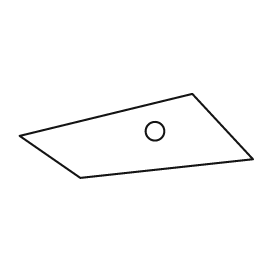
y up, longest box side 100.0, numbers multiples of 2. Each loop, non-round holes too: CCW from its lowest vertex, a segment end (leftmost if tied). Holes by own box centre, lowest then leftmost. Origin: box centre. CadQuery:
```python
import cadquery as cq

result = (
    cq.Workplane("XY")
    .moveTo(-24.0, -18.0)
    .lineTo(50.0, -10.0)
    .lineTo(24.0, 18.0)
    .lineTo(-50.0, 0.0)
    .close()
    .moveTo(8.0, 2.0)
    .circle(4.0)
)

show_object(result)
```